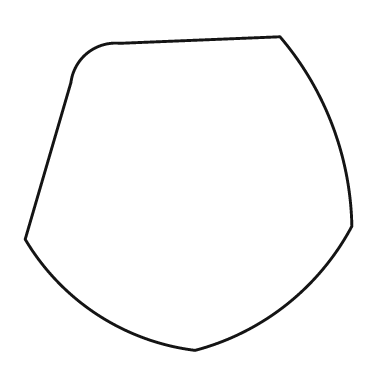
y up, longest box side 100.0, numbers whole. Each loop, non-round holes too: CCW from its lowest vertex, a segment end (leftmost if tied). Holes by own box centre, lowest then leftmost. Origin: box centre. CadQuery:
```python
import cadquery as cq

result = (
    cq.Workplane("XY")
    .moveTo(2.0, -48.0)
    .threePointArc((30.0, -34.0), (50.0, -10.0))
    .threePointArc((44.0, 21.0), (28.0, 48.0))
    .lineTo(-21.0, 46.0)
    .threePointArc((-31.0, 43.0), (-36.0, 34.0))
    .lineTo(-50.0, -14.0)
    .threePointArc((-28.0, -37.0), (2.0, -48.0))
    .close()
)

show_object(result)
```